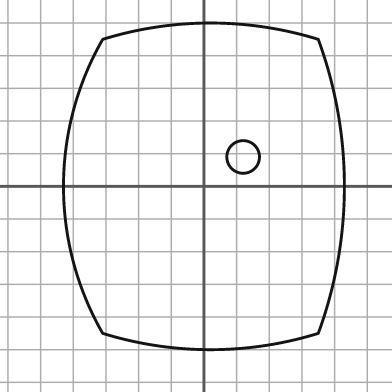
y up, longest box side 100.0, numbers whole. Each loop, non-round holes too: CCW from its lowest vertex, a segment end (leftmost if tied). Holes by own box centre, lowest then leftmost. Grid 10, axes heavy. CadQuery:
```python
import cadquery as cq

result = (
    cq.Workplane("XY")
    .moveTo(-31.0, -45.0)
    .threePointArc((2.0, -50.0), (35.0, -45.0))
    .threePointArc((43.0, 0.0), (35.0, 45.0))
    .threePointArc((2.0, 50.0), (-31.0, 45.0))
    .threePointArc((-43.0, 0.0), (-31.0, -45.0))
    .close()
    .moveTo(12.0, 9.0)
    .circle(5.0)
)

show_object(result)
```